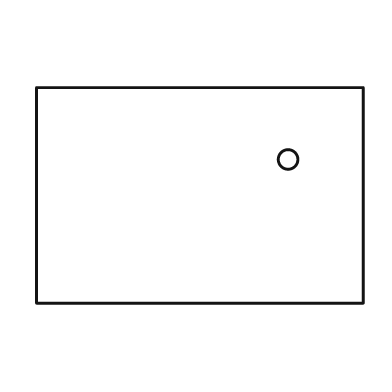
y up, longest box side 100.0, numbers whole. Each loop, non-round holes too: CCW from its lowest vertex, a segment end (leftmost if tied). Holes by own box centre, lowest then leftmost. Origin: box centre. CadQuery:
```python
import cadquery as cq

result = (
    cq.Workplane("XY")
    .moveTo(-50.0, -33.0)
    .lineTo(50.0, -33.0)
    .lineTo(50.0, 33.0)
    .lineTo(-50.0, 33.0)
    .close()
    .moveTo(27.0, 11.0)
    .circle(3.0)
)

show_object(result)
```